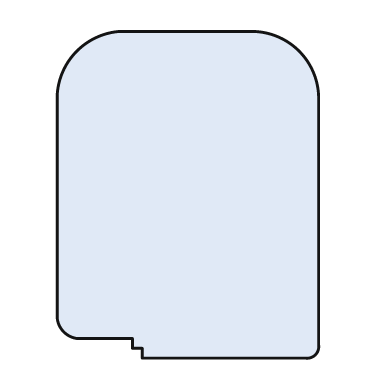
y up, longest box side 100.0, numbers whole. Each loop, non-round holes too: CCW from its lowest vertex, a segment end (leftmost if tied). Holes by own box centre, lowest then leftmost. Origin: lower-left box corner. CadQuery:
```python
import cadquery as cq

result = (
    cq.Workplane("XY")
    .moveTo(26.0, 0.0)
    .lineTo(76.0, 0.0)
    .threePointArc((79.0, 1.0), (80.0, 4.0))
    .lineTo(80.0, 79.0)
    .threePointArc((74.0, 94.0), (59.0, 100.0))
    .lineTo(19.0, 100.0)
    .threePointArc((6.0, 94.0), (0.0, 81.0))
    .lineTo(0.0, 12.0)
    .threePointArc((2.0, 8.0), (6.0, 6.0))
    .lineTo(23.0, 6.0)
    .lineTo(23.0, 3.0)
    .lineTo(26.0, 3.0)
    .close()
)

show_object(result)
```